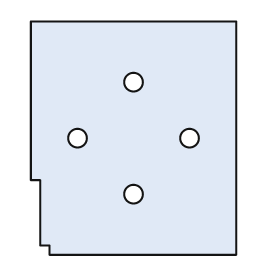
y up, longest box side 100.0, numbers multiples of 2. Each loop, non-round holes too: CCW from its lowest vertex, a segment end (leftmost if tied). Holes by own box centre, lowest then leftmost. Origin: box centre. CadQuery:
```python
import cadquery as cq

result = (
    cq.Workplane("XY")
    .moveTo(-36.0, -50.0)
    .lineTo(44.0, -50.0)
    .lineTo(44.0, 50.0)
    .lineTo(-44.0, 50.0)
    .lineTo(-44.0, -18.0)
    .lineTo(-40.0, -18.0)
    .lineTo(-40.0, -46.0)
    .lineTo(-36.0, -46.0)
    .close()
    .moveTo(0.0, -24.0)
    .circle(4.0)
    .moveTo(-24.0, 0.0)
    .circle(4.0)
    .moveTo(24.0, 0.0)
    .circle(4.0)
    .moveTo(0.0, 24.0)
    .circle(4.0)
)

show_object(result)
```